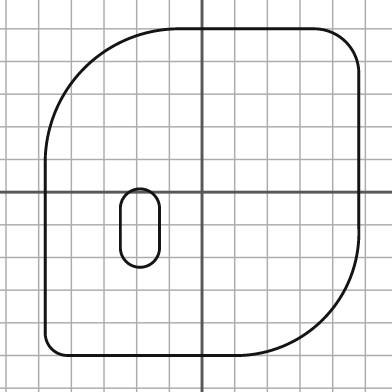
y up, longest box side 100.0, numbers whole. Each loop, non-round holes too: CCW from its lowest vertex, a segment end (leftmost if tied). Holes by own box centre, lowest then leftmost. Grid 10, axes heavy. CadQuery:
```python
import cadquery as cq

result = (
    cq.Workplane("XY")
    .moveTo(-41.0, -50.0)
    .lineTo(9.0, -50.0)
    .threePointArc((37.0, -39.0), (48.0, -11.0))
    .lineTo(48.0, 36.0)
    .threePointArc((44.0, 46.0), (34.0, 50.0))
    .lineTo(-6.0, 50.0)
    .threePointArc((-36.0, 38.0), (-48.0, 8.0))
    .lineTo(-48.0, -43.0)
    .threePointArc((-46.0, -48.0), (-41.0, -50.0))
    .close()
    .moveTo(-25.0, -17.0)
    .threePointArc((-19.0, -23.0), (-13.0, -17.0))
    .lineTo(-13.0, -5.0)
    .threePointArc((-19.0, 1.0), (-25.0, -5.0))
    .close()
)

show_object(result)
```